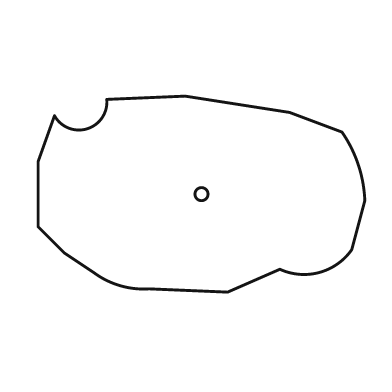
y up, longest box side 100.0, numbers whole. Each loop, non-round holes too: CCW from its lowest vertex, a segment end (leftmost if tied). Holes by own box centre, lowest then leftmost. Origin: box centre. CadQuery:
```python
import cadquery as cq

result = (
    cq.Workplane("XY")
    .moveTo(8.0, -30.0)
    .lineTo(24.0, -23.0)
    .threePointArc((36.0, -24.0), (46.0, -17.0))
    .lineTo(50.0, -2.0)
    .threePointArc((48.0, 9.0), (43.0, 19.0))
    .lineTo(27.0, 25.0)
    .lineTo(-5.0, 30.0)
    .lineTo(-29.0, 29.0)
    .threePointArc((-35.0, 20.0), (-45.0, 24.0))
    .lineTo(-50.0, 10.0)
    .lineTo(-50.0, -10.0)
    .lineTo(-42.0, -18.0)
    .lineTo(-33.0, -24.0)
    .threePointArc((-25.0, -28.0), (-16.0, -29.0))
    .close()
    .moveTo(0.0, 0.0)
    .circle(2.0)
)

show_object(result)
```